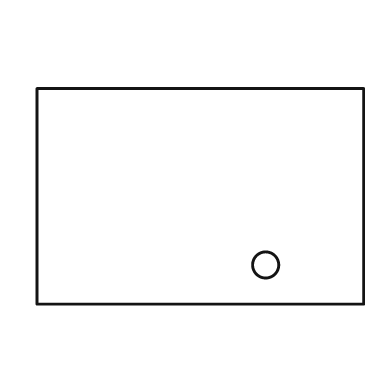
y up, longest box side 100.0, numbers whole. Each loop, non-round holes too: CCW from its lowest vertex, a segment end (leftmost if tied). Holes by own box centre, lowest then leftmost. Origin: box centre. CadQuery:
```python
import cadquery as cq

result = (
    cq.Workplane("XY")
    .moveTo(-50.0, -33.0)
    .lineTo(50.0, -33.0)
    .lineTo(50.0, 33.0)
    .lineTo(-50.0, 33.0)
    .close()
    .moveTo(20.0, -21.0)
    .circle(4.0)
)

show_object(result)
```